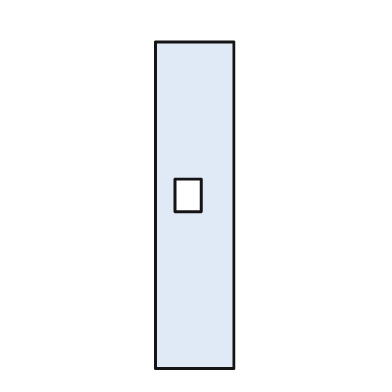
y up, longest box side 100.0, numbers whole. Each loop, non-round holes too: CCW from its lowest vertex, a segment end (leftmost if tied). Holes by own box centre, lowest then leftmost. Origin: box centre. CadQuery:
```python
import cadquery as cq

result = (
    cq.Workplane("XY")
    .moveTo(-12.0, -50.0)
    .lineTo(12.0, -50.0)
    .lineTo(12.0, 50.0)
    .lineTo(-12.0, 50.0)
    .close()
    .moveTo(-6.0, -2.0)
    .lineTo(2.0, -2.0)
    .lineTo(2.0, 8.0)
    .lineTo(-6.0, 8.0)
    .close()
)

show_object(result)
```